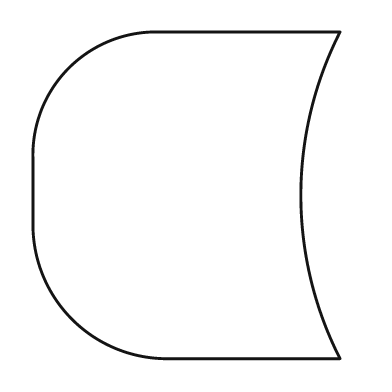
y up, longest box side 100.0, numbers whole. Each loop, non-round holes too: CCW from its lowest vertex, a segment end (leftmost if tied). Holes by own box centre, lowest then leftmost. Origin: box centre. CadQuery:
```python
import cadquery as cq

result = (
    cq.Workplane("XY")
    .moveTo(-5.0, -50.0)
    .lineTo(47.0, -50.0)
    .threePointArc((35.0, 0.0), (47.0, 50.0))
    .lineTo(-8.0, 50.0)
    .threePointArc((-36.0, 39.0), (-47.0, 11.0))
    .lineTo(-47.0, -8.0)
    .threePointArc((-35.0, -38.0), (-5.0, -50.0))
    .close()
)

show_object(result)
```